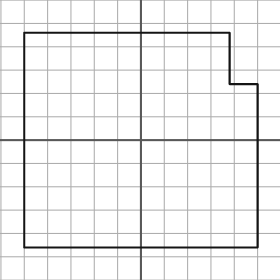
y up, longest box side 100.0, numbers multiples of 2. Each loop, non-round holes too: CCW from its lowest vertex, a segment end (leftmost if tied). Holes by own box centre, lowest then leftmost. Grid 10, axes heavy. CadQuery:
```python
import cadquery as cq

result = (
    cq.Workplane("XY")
    .moveTo(-50.0, -46.0)
    .lineTo(50.0, -46.0)
    .lineTo(50.0, 24.0)
    .lineTo(38.0, 24.0)
    .lineTo(38.0, 46.0)
    .lineTo(-50.0, 46.0)
    .close()
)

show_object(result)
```